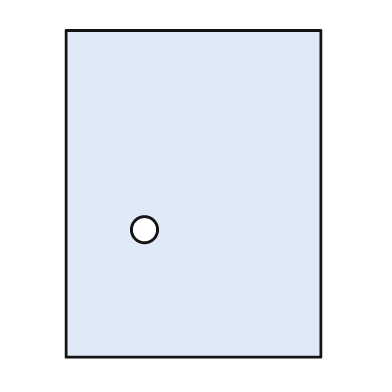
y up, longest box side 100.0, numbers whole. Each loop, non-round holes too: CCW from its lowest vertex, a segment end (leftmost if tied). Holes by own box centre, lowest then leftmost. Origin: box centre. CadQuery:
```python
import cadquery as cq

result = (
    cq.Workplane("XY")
    .moveTo(-39.0, -50.0)
    .lineTo(39.0, -50.0)
    .lineTo(39.0, 50.0)
    .lineTo(-39.0, 50.0)
    .close()
    .moveTo(-15.0, -11.0)
    .circle(4.0)
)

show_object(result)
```